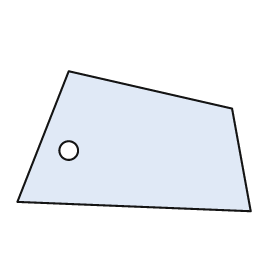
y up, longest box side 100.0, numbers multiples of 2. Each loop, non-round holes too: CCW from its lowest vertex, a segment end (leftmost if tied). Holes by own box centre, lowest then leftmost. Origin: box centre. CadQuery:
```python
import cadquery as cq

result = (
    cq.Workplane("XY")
    .moveTo(50.0, -30.0)
    .lineTo(42.0, 14.0)
    .lineTo(-28.0, 30.0)
    .lineTo(-50.0, -26.0)
    .close()
    .moveTo(-28.0, -4.0)
    .circle(4.0)
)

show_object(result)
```